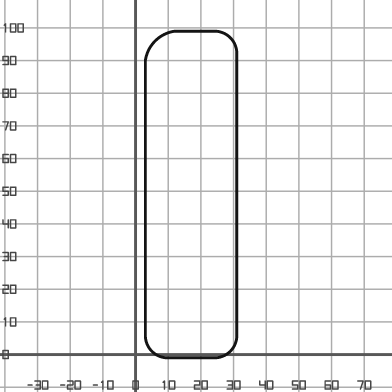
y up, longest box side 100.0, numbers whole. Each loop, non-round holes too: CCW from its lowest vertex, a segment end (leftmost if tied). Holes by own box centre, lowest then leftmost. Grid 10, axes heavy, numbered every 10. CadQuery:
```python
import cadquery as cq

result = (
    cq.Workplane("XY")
    .moveTo(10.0, -1.0)
    .lineTo(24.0, -1.0)
    .threePointArc((29.0, 1.0), (31.0, 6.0))
    .lineTo(31.0, 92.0)
    .threePointArc((29.0, 97.0), (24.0, 99.0))
    .lineTo(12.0, 99.0)
    .threePointArc((6.0, 96.0), (3.0, 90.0))
    .lineTo(3.0, 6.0)
    .threePointArc((5.0, 1.0), (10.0, -1.0))
    .close()
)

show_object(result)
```